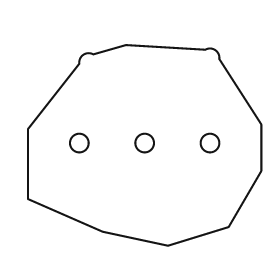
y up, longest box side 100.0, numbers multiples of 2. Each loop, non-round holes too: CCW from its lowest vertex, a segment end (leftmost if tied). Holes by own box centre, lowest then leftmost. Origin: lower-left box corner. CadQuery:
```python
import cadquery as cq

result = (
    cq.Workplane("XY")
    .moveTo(60.0, 0.0)
    .lineTo(86.0, 8.0)
    .lineTo(100.0, 32.0)
    .lineTo(100.0, 52.0)
    .lineTo(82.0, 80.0)
    .threePointArc((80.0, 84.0), (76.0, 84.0))
    .lineTo(42.0, 86.0)
    .lineTo(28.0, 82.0)
    .threePointArc((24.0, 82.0), (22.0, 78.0))
    .lineTo(0.0, 50.0)
    .lineTo(0.0, 20.0)
    .lineTo(32.0, 6.0)
    .close()
    .moveTo(22.0, 44.0)
    .circle(4.0)
    .moveTo(50.0, 44.0)
    .circle(4.0)
    .moveTo(78.0, 44.0)
    .circle(4.0)
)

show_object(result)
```